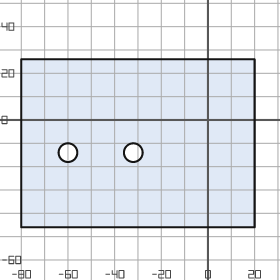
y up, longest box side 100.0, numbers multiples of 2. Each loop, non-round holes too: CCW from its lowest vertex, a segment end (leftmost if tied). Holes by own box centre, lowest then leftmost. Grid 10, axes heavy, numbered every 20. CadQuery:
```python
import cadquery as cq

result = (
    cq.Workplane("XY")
    .moveTo(-80.0, -46.0)
    .lineTo(20.0, -46.0)
    .lineTo(20.0, 26.0)
    .lineTo(-80.0, 26.0)
    .close()
    .moveTo(-60.0, -14.0)
    .circle(4.0)
    .moveTo(-32.0, -14.0)
    .circle(4.0)
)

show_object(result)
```